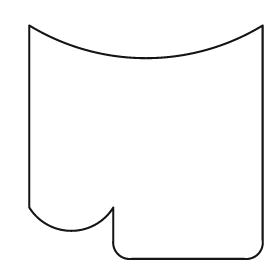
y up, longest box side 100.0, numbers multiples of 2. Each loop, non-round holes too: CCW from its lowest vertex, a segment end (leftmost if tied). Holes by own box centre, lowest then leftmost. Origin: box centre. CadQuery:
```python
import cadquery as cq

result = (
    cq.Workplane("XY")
    .moveTo(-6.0, -50.0)
    .lineTo(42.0, -50.0)
    .threePointArc((48.0, -48.0), (50.0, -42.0))
    .lineTo(50.0, 50.0)
    .threePointArc((0.0, 36.0), (-50.0, 50.0))
    .lineTo(-50.0, -28.0)
    .threePointArc((-32.0, -38.0), (-14.0, -28.0))
    .lineTo(-14.0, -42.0)
    .threePointArc((-12.0, -48.0), (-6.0, -50.0))
    .close()
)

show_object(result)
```